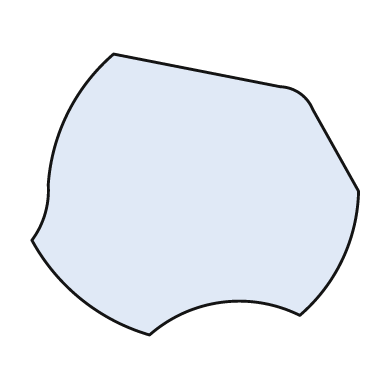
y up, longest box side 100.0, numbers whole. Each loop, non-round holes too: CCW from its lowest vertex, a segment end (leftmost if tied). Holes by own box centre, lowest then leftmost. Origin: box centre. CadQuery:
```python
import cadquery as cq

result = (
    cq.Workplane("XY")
    .moveTo(-14.0, -43.0)
    .threePointArc((8.0, -33.0), (32.0, -37.0))
    .threePointArc((45.0, -20.0), (50.0, 1.0))
    .lineTo(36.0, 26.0)
    .threePointArc((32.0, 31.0), (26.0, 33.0))
    .lineTo(-25.0, 43.0)
    .threePointArc((-39.0, 25.0), (-45.0, 3.0))
    .threePointArc((-46.0, -6.0), (-50.0, -14.0))
    .threePointArc((-35.0, -32.0), (-14.0, -43.0))
    .close()
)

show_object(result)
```